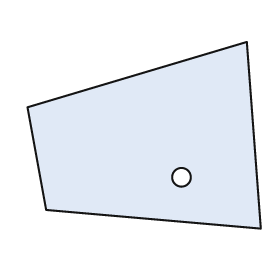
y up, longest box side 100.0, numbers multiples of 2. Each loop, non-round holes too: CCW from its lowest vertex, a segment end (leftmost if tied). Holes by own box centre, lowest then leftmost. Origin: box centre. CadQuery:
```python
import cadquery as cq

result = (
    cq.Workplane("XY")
    .moveTo(50.0, -40.0)
    .lineTo(44.0, 40.0)
    .lineTo(-50.0, 12.0)
    .lineTo(-42.0, -32.0)
    .close()
    .moveTo(16.0, -18.0)
    .circle(4.0)
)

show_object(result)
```